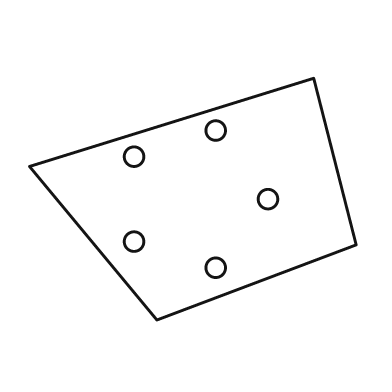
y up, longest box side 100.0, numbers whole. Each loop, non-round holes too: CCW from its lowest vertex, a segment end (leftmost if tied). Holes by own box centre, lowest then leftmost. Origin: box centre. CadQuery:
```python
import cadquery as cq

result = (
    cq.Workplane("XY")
    .moveTo(-11.0, -37.0)
    .lineTo(50.0, -14.0)
    .lineTo(37.0, 37.0)
    .lineTo(-50.0, 10.0)
    .close()
    .moveTo(7.0, -21.0)
    .circle(3.0)
    .moveTo(-18.0, -13.0)
    .circle(3.0)
    .moveTo(23.0, 0.0)
    .circle(3.0)
    .moveTo(-18.0, 13.0)
    .circle(3.0)
    .moveTo(7.0, 21.0)
    .circle(3.0)
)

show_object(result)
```